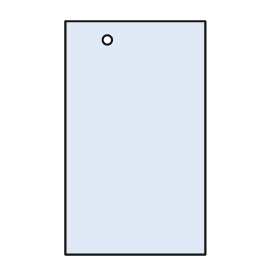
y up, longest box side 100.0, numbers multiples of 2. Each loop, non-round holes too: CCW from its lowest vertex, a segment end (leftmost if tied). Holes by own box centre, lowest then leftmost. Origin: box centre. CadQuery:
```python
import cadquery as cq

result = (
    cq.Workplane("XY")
    .moveTo(-30.0, -50.0)
    .lineTo(30.0, -50.0)
    .lineTo(30.0, 50.0)
    .lineTo(-30.0, 50.0)
    .close()
    .moveTo(-12.0, 42.0)
    .circle(2.0)
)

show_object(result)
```